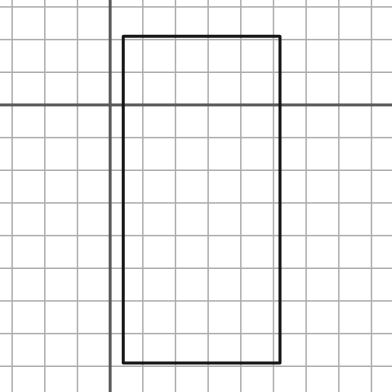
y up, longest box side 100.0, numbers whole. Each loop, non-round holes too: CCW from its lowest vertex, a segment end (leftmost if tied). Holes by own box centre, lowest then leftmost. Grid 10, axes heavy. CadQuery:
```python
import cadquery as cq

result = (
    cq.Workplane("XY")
    .moveTo(4.0, -79.0)
    .lineTo(52.0, -79.0)
    .lineTo(52.0, 21.0)
    .lineTo(4.0, 21.0)
    .close()
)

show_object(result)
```